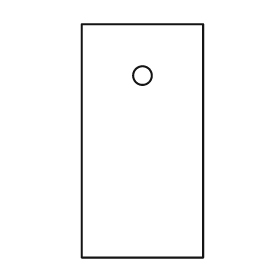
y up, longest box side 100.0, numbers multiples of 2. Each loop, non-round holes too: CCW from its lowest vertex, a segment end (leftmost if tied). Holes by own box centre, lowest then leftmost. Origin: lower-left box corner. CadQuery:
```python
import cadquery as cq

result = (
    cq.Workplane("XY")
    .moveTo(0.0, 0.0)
    .lineTo(52.0, 0.0)
    .lineTo(52.0, 100.0)
    .lineTo(0.0, 100.0)
    .close()
    .moveTo(26.0, 78.0)
    .circle(4.0)
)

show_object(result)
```